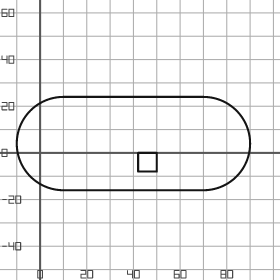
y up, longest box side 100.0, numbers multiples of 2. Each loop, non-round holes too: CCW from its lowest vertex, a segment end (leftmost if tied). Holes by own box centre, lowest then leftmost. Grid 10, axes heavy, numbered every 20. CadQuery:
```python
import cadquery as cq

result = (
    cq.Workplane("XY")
    .moveTo(10.0, -16.0)
    .lineTo(70.0, -16.0)
    .threePointArc((90.0, 4.0), (70.0, 24.0))
    .lineTo(10.0, 24.0)
    .threePointArc((-10.0, 4.0), (10.0, -16.0))
    .close()
    .moveTo(42.0, -8.0)
    .lineTo(50.0, -8.0)
    .lineTo(50.0, 0.0)
    .lineTo(42.0, 0.0)
    .close()
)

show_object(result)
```